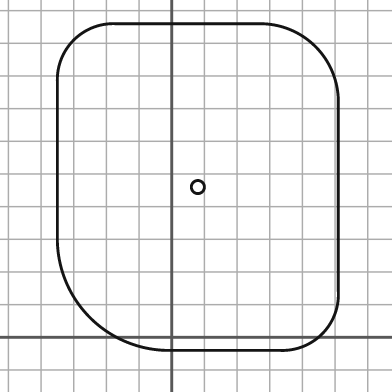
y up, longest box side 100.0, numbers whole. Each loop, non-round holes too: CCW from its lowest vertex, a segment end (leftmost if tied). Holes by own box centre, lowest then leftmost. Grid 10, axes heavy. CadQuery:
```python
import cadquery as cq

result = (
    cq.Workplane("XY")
    .moveTo(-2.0, -4.0)
    .lineTo(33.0, -4.0)
    .threePointArc((46.0, 1.0), (51.0, 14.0))
    .lineTo(51.0, 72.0)
    .threePointArc((44.0, 89.0), (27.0, 96.0))
    .lineTo(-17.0, 96.0)
    .threePointArc((-30.0, 91.0), (-35.0, 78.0))
    .lineTo(-35.0, 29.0)
    .threePointArc((-25.0, 6.0), (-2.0, -4.0))
    .close()
    .moveTo(8.0, 46.0)
    .circle(2.0)
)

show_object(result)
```